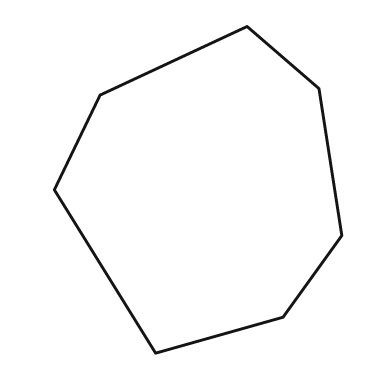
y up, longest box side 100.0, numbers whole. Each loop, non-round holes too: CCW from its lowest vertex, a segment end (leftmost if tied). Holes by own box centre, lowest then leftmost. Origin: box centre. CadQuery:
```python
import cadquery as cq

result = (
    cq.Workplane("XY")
    .moveTo(-13.0, -50.0)
    .lineTo(26.0, -39.0)
    .lineTo(44.0, -14.0)
    .lineTo(37.0, 31.0)
    .lineTo(15.0, 50.0)
    .lineTo(-30.0, 29.0)
    .lineTo(-44.0, 0.0)
    .close()
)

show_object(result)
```